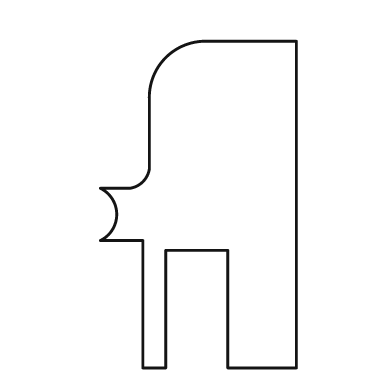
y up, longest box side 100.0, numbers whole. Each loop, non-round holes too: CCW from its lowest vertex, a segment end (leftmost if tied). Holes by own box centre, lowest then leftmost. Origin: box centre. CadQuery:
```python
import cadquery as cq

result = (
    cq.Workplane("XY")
    .moveTo(-17.0, -50.0)
    .lineTo(-10.0, -50.0)
    .lineTo(-10.0, -14.0)
    .lineTo(9.0, -14.0)
    .lineTo(9.0, -50.0)
    .lineTo(30.0, -50.0)
    .lineTo(30.0, 50.0)
    .lineTo(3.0, 50.0)
    .threePointArc((-10.0, 45.0), (-15.0, 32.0))
    .lineTo(-15.0, 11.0)
    .threePointArc((-17.0, 7.0), (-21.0, 5.0))
    .lineTo(-30.0, 5.0)
    .threePointArc((-25.0, -3.0), (-30.0, -11.0))
    .lineTo(-17.0, -11.0)
    .close()
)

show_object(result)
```